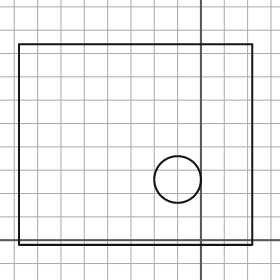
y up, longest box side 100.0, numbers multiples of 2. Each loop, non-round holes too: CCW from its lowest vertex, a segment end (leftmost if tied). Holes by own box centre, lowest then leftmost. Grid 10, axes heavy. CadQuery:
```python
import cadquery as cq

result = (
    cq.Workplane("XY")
    .moveTo(-78.0, -2.0)
    .lineTo(22.0, -2.0)
    .lineTo(22.0, 84.0)
    .lineTo(-78.0, 84.0)
    .close()
    .moveTo(-10.0, 26.0)
    .circle(10.0)
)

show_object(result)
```